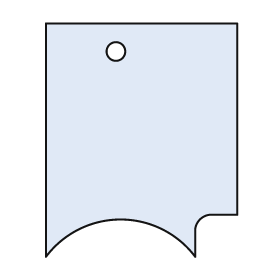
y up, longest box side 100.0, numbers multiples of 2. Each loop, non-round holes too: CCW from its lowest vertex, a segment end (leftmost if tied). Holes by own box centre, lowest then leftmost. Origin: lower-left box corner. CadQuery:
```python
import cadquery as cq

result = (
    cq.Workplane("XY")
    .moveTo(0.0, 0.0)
    .threePointArc((32.0, 16.0), (64.0, 0.0))
    .lineTo(64.0, 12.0)
    .threePointArc((66.0, 16.0), (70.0, 18.0))
    .lineTo(82.0, 18.0)
    .lineTo(82.0, 100.0)
    .lineTo(0.0, 100.0)
    .close()
    .moveTo(30.0, 88.0)
    .circle(4.0)
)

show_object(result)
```